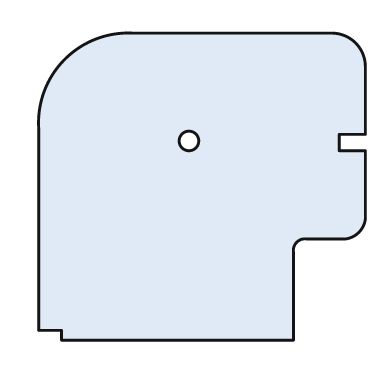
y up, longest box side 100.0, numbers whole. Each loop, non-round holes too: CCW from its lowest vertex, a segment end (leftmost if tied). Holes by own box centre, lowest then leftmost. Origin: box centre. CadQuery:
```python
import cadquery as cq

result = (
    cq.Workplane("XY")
    .moveTo(-43.0, -47.0)
    .lineTo(28.0, -47.0)
    .lineTo(28.0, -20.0)
    .threePointArc((29.0, -17.0), (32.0, -16.0))
    .lineTo(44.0, -16.0)
    .threePointArc((48.0, -14.0), (50.0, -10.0))
    .lineTo(50.0, 11.0)
    .lineTo(42.0, 11.0)
    .lineTo(42.0, 16.0)
    .lineTo(50.0, 16.0)
    .lineTo(50.0, 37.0)
    .threePointArc((47.0, 44.0), (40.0, 47.0))
    .lineTo(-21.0, 47.0)
    .threePointArc((-42.0, 39.0), (-50.0, 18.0))
    .lineTo(-50.0, -44.0)
    .lineTo(-43.0, -44.0)
    .close()
    .moveTo(-4.0, 14.0)
    .circle(3.0)
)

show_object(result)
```